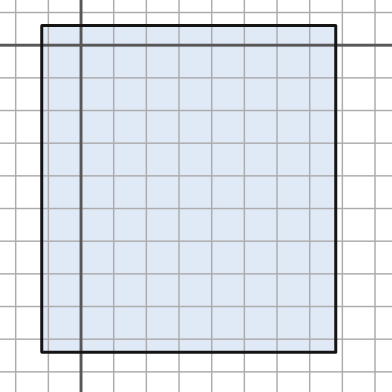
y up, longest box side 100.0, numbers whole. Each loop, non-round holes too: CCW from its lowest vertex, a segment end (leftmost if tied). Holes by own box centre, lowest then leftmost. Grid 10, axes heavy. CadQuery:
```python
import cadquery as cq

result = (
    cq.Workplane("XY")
    .moveTo(-12.0, -94.0)
    .lineTo(78.0, -94.0)
    .lineTo(78.0, 6.0)
    .lineTo(-12.0, 6.0)
    .close()
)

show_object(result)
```